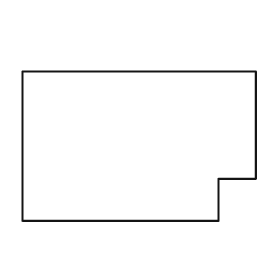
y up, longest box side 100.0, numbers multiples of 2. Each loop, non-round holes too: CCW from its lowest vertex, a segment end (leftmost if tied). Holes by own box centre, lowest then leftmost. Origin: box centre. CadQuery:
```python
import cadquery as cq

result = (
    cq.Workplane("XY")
    .moveTo(-50.0, -32.0)
    .lineTo(34.0, -32.0)
    .lineTo(34.0, -14.0)
    .lineTo(50.0, -14.0)
    .lineTo(50.0, 32.0)
    .lineTo(-50.0, 32.0)
    .close()
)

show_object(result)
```